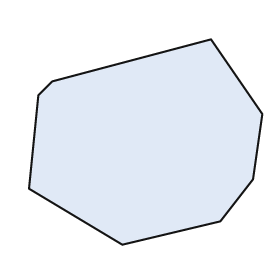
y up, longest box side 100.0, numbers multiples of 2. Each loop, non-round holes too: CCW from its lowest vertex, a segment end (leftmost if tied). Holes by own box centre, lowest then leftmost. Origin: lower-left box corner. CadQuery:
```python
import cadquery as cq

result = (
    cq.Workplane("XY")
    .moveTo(40.0, 0.0)
    .lineTo(82.0, 10.0)
    .lineTo(96.0, 28.0)
    .lineTo(100.0, 56.0)
    .lineTo(78.0, 88.0)
    .lineTo(10.0, 70.0)
    .lineTo(4.0, 64.0)
    .lineTo(0.0, 24.0)
    .close()
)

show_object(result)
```